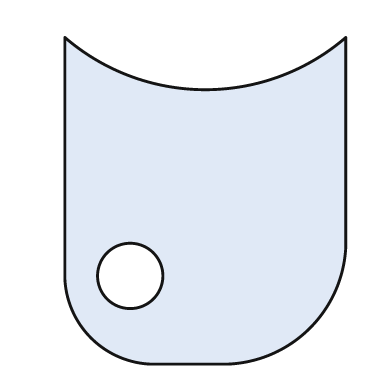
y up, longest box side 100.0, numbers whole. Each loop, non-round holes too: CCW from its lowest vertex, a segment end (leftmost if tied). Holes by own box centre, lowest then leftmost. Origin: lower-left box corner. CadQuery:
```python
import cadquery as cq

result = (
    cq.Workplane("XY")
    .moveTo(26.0, 0.0)
    .lineTo(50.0, 0.0)
    .threePointArc((75.0, 11.0), (86.0, 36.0))
    .lineTo(86.0, 100.0)
    .threePointArc((43.0, 84.0), (0.0, 100.0))
    .lineTo(0.0, 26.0)
    .threePointArc((8.0, 8.0), (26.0, 0.0))
    .close()
    .moveTo(20.0, 27.0)
    .circle(10.0)
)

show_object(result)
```